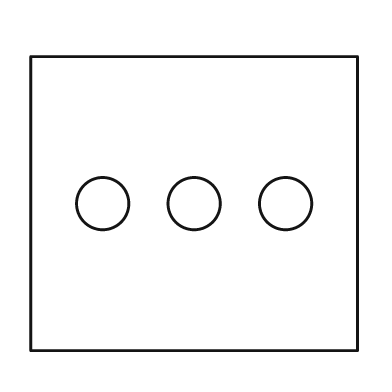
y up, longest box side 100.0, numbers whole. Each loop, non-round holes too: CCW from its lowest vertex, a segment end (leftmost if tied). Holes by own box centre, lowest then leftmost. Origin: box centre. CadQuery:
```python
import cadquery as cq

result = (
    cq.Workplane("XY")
    .moveTo(-50.0, -45.0)
    .lineTo(50.0, -45.0)
    .lineTo(50.0, 45.0)
    .lineTo(-50.0, 45.0)
    .close()
    .moveTo(-28.0, 0.0)
    .circle(8.0)
    .moveTo(0.0, 0.0)
    .circle(8.0)
    .moveTo(28.0, 0.0)
    .circle(8.0)
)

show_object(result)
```